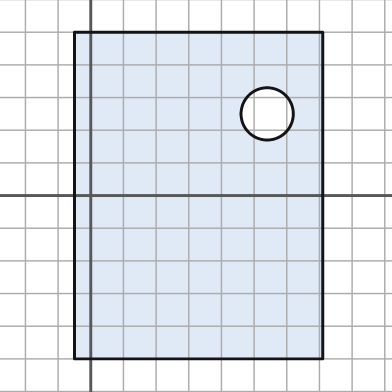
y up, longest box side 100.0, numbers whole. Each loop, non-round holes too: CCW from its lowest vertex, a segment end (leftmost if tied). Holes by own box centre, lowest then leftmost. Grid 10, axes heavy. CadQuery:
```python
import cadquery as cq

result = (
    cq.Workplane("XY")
    .moveTo(-5.0, -50.0)
    .lineTo(71.0, -50.0)
    .lineTo(71.0, 50.0)
    .lineTo(-5.0, 50.0)
    .close()
    .moveTo(54.0, 25.0)
    .circle(8.0)
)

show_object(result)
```